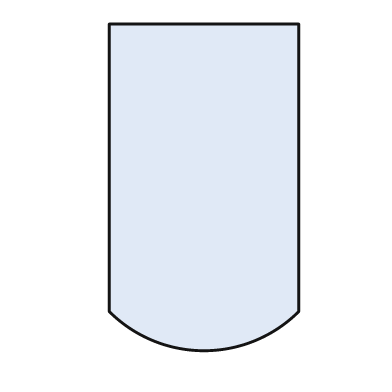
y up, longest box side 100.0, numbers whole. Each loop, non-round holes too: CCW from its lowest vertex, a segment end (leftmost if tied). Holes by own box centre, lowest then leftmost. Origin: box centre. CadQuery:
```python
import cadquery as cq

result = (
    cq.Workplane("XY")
    .moveTo(-29.0, -38.0)
    .threePointArc((0.0, -50.0), (29.0, -38.0))
    .lineTo(29.0, 50.0)
    .lineTo(-29.0, 50.0)
    .close()
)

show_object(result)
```